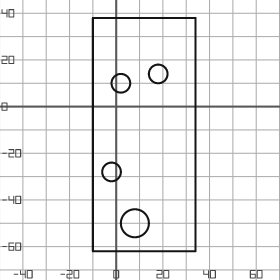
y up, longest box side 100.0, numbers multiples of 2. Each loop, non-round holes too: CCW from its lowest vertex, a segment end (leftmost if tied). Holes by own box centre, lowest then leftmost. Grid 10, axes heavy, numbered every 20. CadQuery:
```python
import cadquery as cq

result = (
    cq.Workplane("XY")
    .moveTo(-10.0, -62.0)
    .lineTo(34.0, -62.0)
    .lineTo(34.0, 38.0)
    .lineTo(-10.0, 38.0)
    .close()
    .moveTo(8.0, -50.0)
    .circle(6.0)
    .moveTo(-2.0, -28.0)
    .circle(4.0)
    .moveTo(2.0, 10.0)
    .circle(4.0)
    .moveTo(18.0, 14.0)
    .circle(4.0)
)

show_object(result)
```